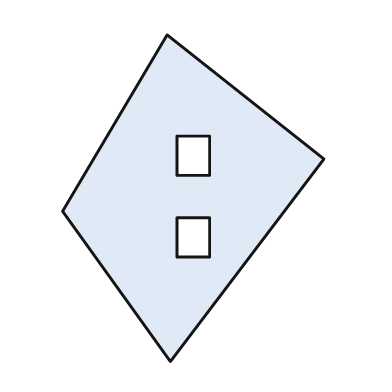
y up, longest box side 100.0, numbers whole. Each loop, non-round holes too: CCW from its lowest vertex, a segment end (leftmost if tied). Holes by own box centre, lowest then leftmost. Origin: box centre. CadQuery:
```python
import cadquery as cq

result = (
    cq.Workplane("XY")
    .moveTo(-7.0, -50.0)
    .lineTo(40.0, 12.0)
    .lineTo(-8.0, 50.0)
    .lineTo(-40.0, -4.0)
    .close()
    .moveTo(-5.0, -18.0)
    .lineTo(5.0, -18.0)
    .lineTo(5.0, -6.0)
    .lineTo(-5.0, -6.0)
    .close()
    .moveTo(-5.0, 7.0)
    .lineTo(5.0, 7.0)
    .lineTo(5.0, 19.0)
    .lineTo(-5.0, 19.0)
    .close()
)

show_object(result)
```